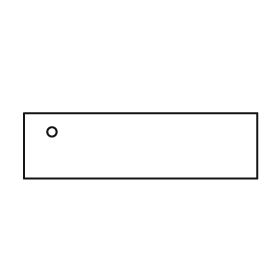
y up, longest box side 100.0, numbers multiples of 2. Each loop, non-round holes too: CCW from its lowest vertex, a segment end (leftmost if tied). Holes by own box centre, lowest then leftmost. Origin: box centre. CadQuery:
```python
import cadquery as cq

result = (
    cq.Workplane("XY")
    .moveTo(-50.0, -14.0)
    .lineTo(50.0, -14.0)
    .lineTo(50.0, 14.0)
    .lineTo(-50.0, 14.0)
    .close()
    .moveTo(-38.0, 6.0)
    .circle(2.0)
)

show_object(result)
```